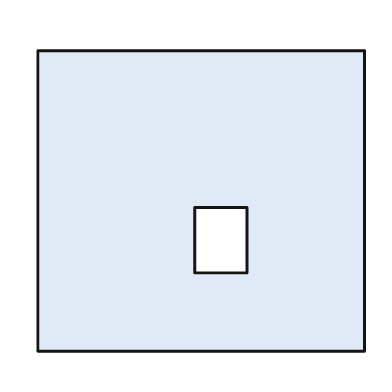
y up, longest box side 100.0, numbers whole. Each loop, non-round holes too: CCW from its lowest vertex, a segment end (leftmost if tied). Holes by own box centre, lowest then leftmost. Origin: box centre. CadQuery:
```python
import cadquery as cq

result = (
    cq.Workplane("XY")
    .moveTo(-50.0, -46.0)
    .lineTo(50.0, -46.0)
    .lineTo(50.0, 46.0)
    .lineTo(-50.0, 46.0)
    .close()
    .moveTo(-2.0, -22.0)
    .lineTo(14.0, -22.0)
    .lineTo(14.0, -2.0)
    .lineTo(-2.0, -2.0)
    .close()
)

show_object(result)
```